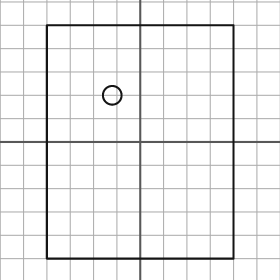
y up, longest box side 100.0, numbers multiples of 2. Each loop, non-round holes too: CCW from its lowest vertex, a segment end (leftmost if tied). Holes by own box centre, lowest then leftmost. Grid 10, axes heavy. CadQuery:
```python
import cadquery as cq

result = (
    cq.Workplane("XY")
    .moveTo(-40.0, -50.0)
    .lineTo(40.0, -50.0)
    .lineTo(40.0, 50.0)
    .lineTo(-40.0, 50.0)
    .close()
    .moveTo(-12.0, 20.0)
    .circle(4.0)
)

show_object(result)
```